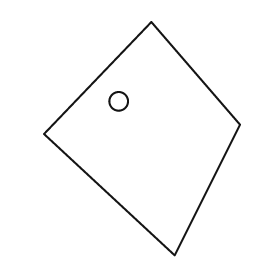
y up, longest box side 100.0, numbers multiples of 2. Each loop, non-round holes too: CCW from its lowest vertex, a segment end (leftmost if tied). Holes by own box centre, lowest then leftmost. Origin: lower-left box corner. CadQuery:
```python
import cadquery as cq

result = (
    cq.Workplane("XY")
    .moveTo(56.0, 0.0)
    .lineTo(84.0, 56.0)
    .lineTo(46.0, 100.0)
    .lineTo(0.0, 52.0)
    .close()
    .moveTo(32.0, 66.0)
    .circle(4.0)
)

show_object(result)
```